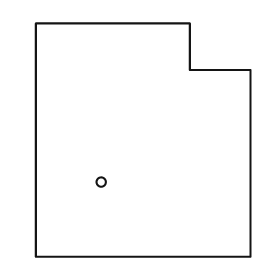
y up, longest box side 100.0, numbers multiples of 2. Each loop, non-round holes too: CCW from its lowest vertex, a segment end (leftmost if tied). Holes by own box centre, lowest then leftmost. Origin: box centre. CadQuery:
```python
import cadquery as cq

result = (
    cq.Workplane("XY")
    .moveTo(-46.0, -50.0)
    .lineTo(46.0, -50.0)
    .lineTo(46.0, 30.0)
    .lineTo(20.0, 30.0)
    .lineTo(20.0, 50.0)
    .lineTo(-46.0, 50.0)
    .close()
    .moveTo(-18.0, -18.0)
    .circle(2.0)
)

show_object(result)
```